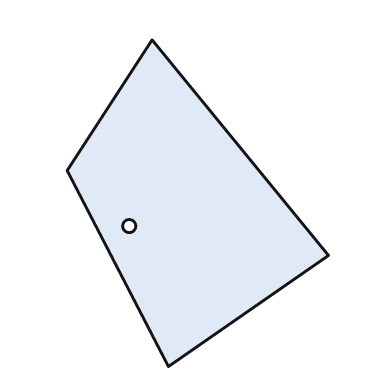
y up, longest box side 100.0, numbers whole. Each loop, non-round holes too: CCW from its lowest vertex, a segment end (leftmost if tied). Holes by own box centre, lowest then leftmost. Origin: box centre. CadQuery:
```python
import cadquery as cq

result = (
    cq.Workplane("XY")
    .moveTo(-9.0, -50.0)
    .lineTo(40.0, -16.0)
    .lineTo(-14.0, 50.0)
    .lineTo(-40.0, 10.0)
    .close()
    .moveTo(-21.0, -7.0)
    .circle(2.0)
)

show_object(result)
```